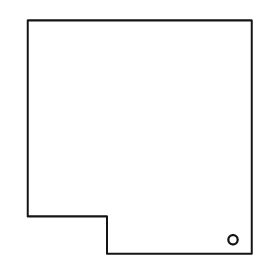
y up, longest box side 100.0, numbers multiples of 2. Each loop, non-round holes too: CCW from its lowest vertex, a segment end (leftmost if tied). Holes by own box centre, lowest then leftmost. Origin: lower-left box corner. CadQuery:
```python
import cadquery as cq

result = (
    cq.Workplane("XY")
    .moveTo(34.0, 0.0)
    .lineTo(96.0, 0.0)
    .lineTo(96.0, 100.0)
    .lineTo(0.0, 100.0)
    .lineTo(0.0, 16.0)
    .lineTo(34.0, 16.0)
    .close()
    .moveTo(88.0, 6.0)
    .circle(2.0)
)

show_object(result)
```